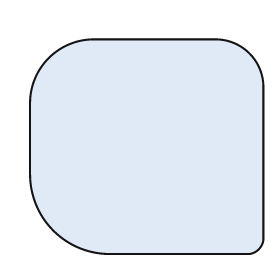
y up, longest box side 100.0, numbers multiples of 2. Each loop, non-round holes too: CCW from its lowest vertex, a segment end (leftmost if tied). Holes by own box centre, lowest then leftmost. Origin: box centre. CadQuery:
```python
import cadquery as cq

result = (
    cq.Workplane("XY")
    .moveTo(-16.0, -46.0)
    .lineTo(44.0, -46.0)
    .threePointArc((48.0, -44.0), (50.0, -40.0))
    .lineTo(50.0, 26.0)
    .threePointArc((44.0, 40.0), (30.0, 46.0))
    .lineTo(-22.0, 46.0)
    .threePointArc((-42.0, 38.0), (-50.0, 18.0))
    .lineTo(-50.0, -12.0)
    .threePointArc((-40.0, -36.0), (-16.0, -46.0))
    .close()
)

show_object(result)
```